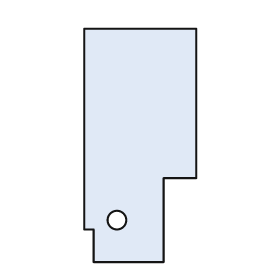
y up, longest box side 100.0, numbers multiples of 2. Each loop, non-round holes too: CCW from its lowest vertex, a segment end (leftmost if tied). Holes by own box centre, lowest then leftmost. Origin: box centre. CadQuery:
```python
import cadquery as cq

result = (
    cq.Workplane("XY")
    .moveTo(-20.0, -50.0)
    .lineTo(10.0, -50.0)
    .lineTo(10.0, -14.0)
    .lineTo(24.0, -14.0)
    .lineTo(24.0, 50.0)
    .lineTo(-24.0, 50.0)
    .lineTo(-24.0, -36.0)
    .lineTo(-20.0, -36.0)
    .close()
    .moveTo(-10.0, -32.0)
    .circle(4.0)
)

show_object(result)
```